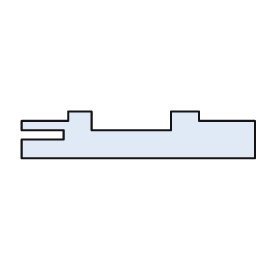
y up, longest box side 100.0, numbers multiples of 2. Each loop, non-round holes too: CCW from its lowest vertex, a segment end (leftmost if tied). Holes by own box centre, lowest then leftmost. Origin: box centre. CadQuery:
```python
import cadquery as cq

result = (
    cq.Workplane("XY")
    .moveTo(-50.0, -10.0)
    .lineTo(50.0, -10.0)
    .lineTo(50.0, 6.0)
    .lineTo(26.0, 6.0)
    .lineTo(26.0, 10.0)
    .lineTo(14.0, 10.0)
    .lineTo(14.0, 2.0)
    .lineTo(-20.0, 2.0)
    .lineTo(-20.0, 10.0)
    .lineTo(-30.0, 10.0)
    .lineTo(-30.0, 6.0)
    .lineTo(-50.0, 6.0)
    .lineTo(-50.0, 2.0)
    .lineTo(-32.0, 2.0)
    .lineTo(-32.0, -2.0)
    .lineTo(-50.0, -2.0)
    .close()
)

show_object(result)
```